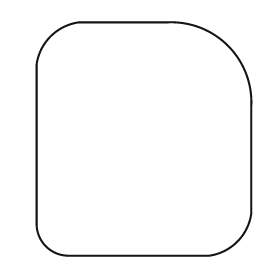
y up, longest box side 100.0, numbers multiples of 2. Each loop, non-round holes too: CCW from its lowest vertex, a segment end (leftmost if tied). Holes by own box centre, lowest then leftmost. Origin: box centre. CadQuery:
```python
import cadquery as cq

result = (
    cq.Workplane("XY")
    .moveTo(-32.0, -50.0)
    .lineTo(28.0, -50.0)
    .threePointArc((40.0, -44.0), (46.0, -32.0))
    .lineTo(46.0, 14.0)
    .threePointArc((36.0, 40.0), (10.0, 50.0))
    .lineTo(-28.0, 50.0)
    .threePointArc((-40.0, 44.0), (-46.0, 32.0))
    .lineTo(-46.0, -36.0)
    .threePointArc((-42.0, -46.0), (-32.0, -50.0))
    .close()
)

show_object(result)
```